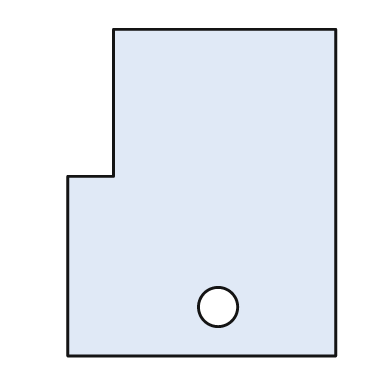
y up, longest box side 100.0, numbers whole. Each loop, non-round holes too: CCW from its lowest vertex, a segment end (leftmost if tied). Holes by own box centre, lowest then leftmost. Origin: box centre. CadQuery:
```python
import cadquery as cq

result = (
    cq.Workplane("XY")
    .moveTo(-41.0, -50.0)
    .lineTo(41.0, -50.0)
    .lineTo(41.0, 50.0)
    .lineTo(-27.0, 50.0)
    .lineTo(-27.0, 5.0)
    .lineTo(-41.0, 5.0)
    .close()
    .moveTo(5.0, -35.0)
    .circle(6.0)
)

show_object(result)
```